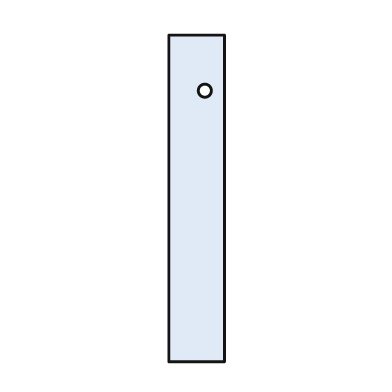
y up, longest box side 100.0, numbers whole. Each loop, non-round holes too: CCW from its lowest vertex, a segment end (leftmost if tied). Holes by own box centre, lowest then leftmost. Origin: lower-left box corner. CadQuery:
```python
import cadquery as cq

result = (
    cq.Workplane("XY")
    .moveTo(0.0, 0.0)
    .lineTo(17.0, 0.0)
    .lineTo(17.0, 100.0)
    .lineTo(0.0, 100.0)
    .close()
    .moveTo(11.0, 83.0)
    .circle(2.0)
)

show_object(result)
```